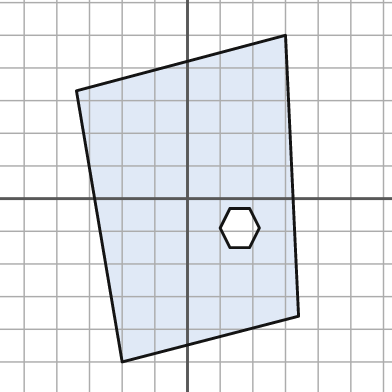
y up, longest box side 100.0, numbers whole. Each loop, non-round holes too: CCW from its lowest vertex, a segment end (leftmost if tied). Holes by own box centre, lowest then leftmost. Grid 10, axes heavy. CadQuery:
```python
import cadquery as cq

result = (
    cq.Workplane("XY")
    .moveTo(-20.0, -50.0)
    .lineTo(34.0, -36.0)
    .lineTo(30.0, 50.0)
    .lineTo(-34.0, 33.0)
    .close()
    .moveTo(13.0, -15.0)
    .lineTo(19.0, -15.0)
    .lineTo(22.0, -9.0)
    .lineTo(19.0, -3.0)
    .lineTo(13.0, -3.0)
    .lineTo(10.0, -9.0)
    .close()
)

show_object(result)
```